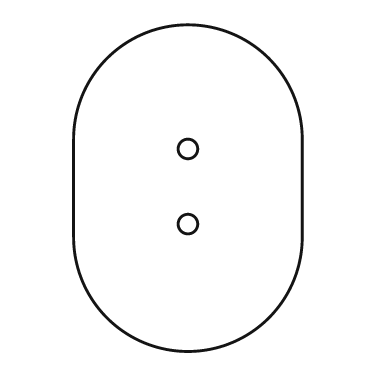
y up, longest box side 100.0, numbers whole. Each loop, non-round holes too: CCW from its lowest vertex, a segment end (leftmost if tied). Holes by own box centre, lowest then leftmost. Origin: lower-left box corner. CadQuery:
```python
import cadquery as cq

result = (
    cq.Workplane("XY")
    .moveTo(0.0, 35.0)
    .threePointArc((35.0, 0.0), (70.0, 35.0))
    .lineTo(70.0, 65.0)
    .threePointArc((35.0, 100.0), (0.0, 65.0))
    .close()
    .moveTo(35.0, 39.0)
    .circle(3.0)
    .moveTo(35.0, 62.0)
    .circle(3.0)
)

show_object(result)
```